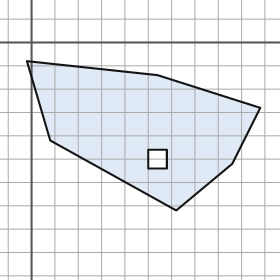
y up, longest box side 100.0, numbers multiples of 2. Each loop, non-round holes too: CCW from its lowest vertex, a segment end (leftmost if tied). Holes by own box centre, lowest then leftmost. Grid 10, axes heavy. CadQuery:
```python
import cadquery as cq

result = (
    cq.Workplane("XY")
    .moveTo(62.0, -72.0)
    .lineTo(86.0, -52.0)
    .lineTo(98.0, -28.0)
    .lineTo(54.0, -14.0)
    .lineTo(-2.0, -8.0)
    .lineTo(8.0, -42.0)
    .close()
    .moveTo(50.0, -54.0)
    .lineTo(58.0, -54.0)
    .lineTo(58.0, -46.0)
    .lineTo(50.0, -46.0)
    .close()
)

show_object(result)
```